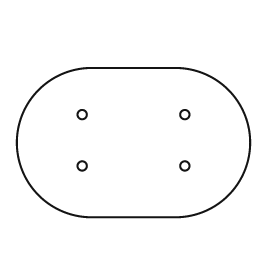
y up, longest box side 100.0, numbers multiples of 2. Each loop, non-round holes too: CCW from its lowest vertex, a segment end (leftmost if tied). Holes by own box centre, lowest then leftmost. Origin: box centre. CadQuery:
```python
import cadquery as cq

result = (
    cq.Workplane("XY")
    .moveTo(-18.0, -32.0)
    .lineTo(18.0, -32.0)
    .threePointArc((50.0, 0.0), (18.0, 32.0))
    .lineTo(-18.0, 32.0)
    .threePointArc((-50.0, 0.0), (-18.0, -32.0))
    .close()
    .moveTo(-22.0, -10.0)
    .circle(2.0)
    .moveTo(22.0, -10.0)
    .circle(2.0)
    .moveTo(-22.0, 12.0)
    .circle(2.0)
    .moveTo(22.0, 12.0)
    .circle(2.0)
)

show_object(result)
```